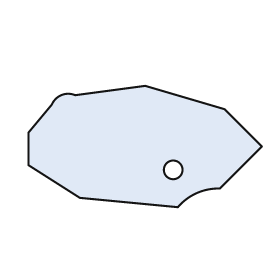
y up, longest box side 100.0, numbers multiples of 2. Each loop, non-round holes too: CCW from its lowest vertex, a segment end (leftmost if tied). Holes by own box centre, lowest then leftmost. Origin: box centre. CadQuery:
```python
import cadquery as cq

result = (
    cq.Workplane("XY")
    .moveTo(14.0, -26.0)
    .threePointArc((22.0, -20.0), (32.0, -18.0))
    .lineTo(50.0, 0.0)
    .lineTo(34.0, 16.0)
    .lineTo(0.0, 26.0)
    .lineTo(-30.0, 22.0)
    .threePointArc((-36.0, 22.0), (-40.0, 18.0))
    .lineTo(-50.0, 6.0)
    .lineTo(-50.0, -8.0)
    .lineTo(-28.0, -22.0)
    .close()
    .moveTo(12.0, -10.0)
    .circle(4.0)
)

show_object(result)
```